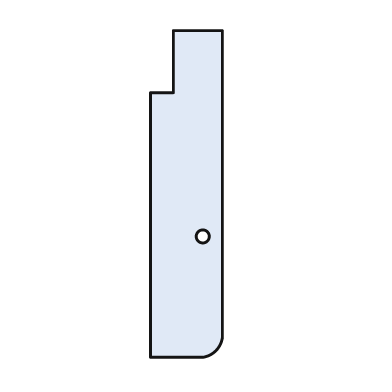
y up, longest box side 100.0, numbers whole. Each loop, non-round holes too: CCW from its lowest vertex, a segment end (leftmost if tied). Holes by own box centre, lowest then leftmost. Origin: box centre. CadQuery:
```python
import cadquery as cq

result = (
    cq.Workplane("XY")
    .moveTo(-11.0, -50.0)
    .lineTo(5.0, -50.0)
    .threePointArc((9.0, -48.0), (11.0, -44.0))
    .lineTo(11.0, 50.0)
    .lineTo(-4.0, 50.0)
    .lineTo(-4.0, 31.0)
    .lineTo(-11.0, 31.0)
    .close()
    .moveTo(5.0, -13.0)
    .circle(2.0)
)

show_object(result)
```